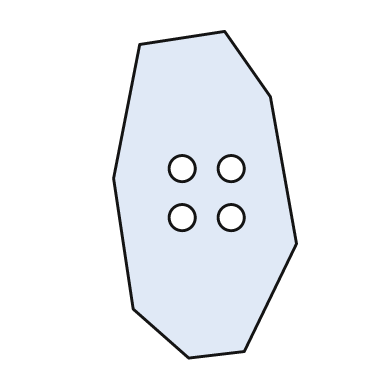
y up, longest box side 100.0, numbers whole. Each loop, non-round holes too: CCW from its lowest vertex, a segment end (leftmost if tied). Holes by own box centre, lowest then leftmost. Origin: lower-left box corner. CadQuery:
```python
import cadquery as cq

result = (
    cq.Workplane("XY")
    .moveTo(23.0, 0.0)
    .lineTo(40.0, 2.0)
    .lineTo(56.0, 35.0)
    .lineTo(48.0, 80.0)
    .lineTo(34.0, 100.0)
    .lineTo(8.0, 96.0)
    .lineTo(0.0, 55.0)
    .lineTo(6.0, 15.0)
    .close()
    .moveTo(21.0, 43.0)
    .circle(4.0)
    .moveTo(36.0, 43.0)
    .circle(4.0)
    .moveTo(21.0, 58.0)
    .circle(4.0)
    .moveTo(36.0, 58.0)
    .circle(4.0)
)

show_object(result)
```